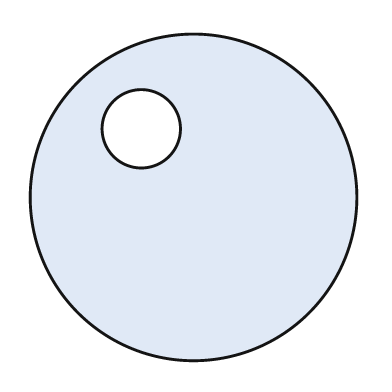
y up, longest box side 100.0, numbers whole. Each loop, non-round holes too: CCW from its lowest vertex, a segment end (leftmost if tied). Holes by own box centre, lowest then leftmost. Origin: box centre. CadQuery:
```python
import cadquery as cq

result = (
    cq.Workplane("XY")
    .moveTo(0.0, 0.0)
    .circle(50.0)
    .moveTo(-16.0, 21.0)
    .circle(12.0)
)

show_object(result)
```